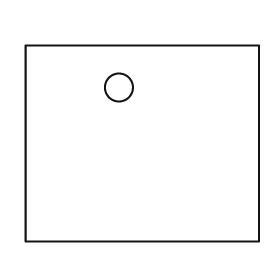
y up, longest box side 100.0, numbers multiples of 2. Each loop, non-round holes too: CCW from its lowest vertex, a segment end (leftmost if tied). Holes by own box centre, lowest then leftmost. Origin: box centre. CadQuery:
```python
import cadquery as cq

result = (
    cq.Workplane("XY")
    .moveTo(-50.0, -42.0)
    .lineTo(50.0, -42.0)
    .lineTo(50.0, 42.0)
    .lineTo(-50.0, 42.0)
    .close()
    .moveTo(-10.0, 24.0)
    .circle(6.0)
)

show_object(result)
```